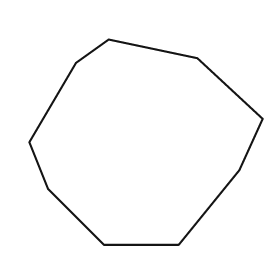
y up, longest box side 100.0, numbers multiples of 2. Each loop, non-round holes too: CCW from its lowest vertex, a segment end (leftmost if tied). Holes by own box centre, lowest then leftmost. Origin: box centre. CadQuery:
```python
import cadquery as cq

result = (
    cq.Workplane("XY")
    .moveTo(-18.0, -44.0)
    .lineTo(14.0, -44.0)
    .lineTo(40.0, -12.0)
    .lineTo(50.0, 10.0)
    .lineTo(22.0, 36.0)
    .lineTo(-16.0, 44.0)
    .lineTo(-30.0, 34.0)
    .lineTo(-50.0, 0.0)
    .lineTo(-42.0, -20.0)
    .close()
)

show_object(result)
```